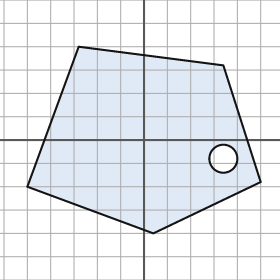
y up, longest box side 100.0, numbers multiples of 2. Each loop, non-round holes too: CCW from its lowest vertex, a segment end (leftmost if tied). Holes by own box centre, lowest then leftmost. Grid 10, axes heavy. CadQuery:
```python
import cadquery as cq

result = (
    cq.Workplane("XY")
    .moveTo(4.0, -40.0)
    .lineTo(50.0, -18.0)
    .lineTo(34.0, 32.0)
    .lineTo(-28.0, 40.0)
    .lineTo(-50.0, -20.0)
    .close()
    .moveTo(34.0, -8.0)
    .circle(6.0)
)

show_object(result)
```